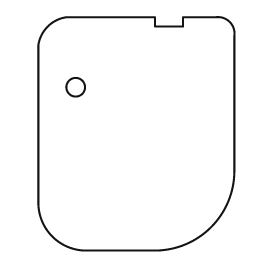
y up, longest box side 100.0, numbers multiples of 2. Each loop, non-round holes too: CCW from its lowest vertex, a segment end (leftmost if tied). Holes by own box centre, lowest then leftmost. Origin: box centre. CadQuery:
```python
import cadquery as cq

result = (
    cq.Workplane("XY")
    .moveTo(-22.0, -50.0)
    .lineTo(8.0, -50.0)
    .threePointArc((32.0, -40.0), (42.0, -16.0))
    .lineTo(42.0, 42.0)
    .threePointArc((40.0, 48.0), (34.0, 50.0))
    .lineTo(20.0, 50.0)
    .lineTo(20.0, 46.0)
    .lineTo(8.0, 46.0)
    .lineTo(8.0, 50.0)
    .lineTo(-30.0, 50.0)
    .threePointArc((-38.0, 46.0), (-42.0, 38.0))
    .lineTo(-42.0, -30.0)
    .threePointArc((-36.0, -44.0), (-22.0, -50.0))
    .close()
    .moveTo(-26.0, 20.0)
    .circle(4.0)
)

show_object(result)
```